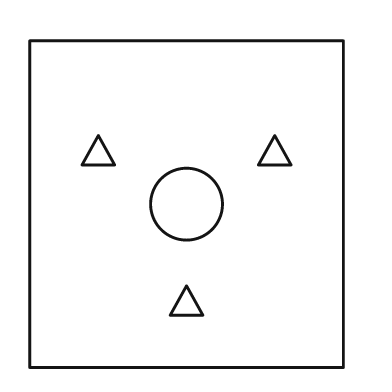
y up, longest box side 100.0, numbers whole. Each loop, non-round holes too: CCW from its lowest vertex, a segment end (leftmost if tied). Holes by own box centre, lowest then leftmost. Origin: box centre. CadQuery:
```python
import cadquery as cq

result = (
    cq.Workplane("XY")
    .moveTo(-48.0, -50.0)
    .lineTo(48.0, -50.0)
    .lineTo(48.0, 50.0)
    .lineTo(-48.0, 50.0)
    .close()
    .moveTo(-5.0, -34.0)
    .lineTo(5.0, -34.0)
    .lineTo(0.0, -25.0)
    .close()
    .moveTo(0.0, 0.0)
    .circle(11.0)
    .moveTo(-32.0, 12.0)
    .lineTo(-22.0, 12.0)
    .lineTo(-27.0, 21.0)
    .close()
    .moveTo(22.0, 12.0)
    .lineTo(32.0, 12.0)
    .lineTo(27.0, 21.0)
    .close()
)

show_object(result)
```